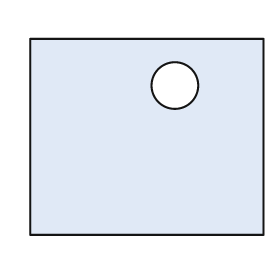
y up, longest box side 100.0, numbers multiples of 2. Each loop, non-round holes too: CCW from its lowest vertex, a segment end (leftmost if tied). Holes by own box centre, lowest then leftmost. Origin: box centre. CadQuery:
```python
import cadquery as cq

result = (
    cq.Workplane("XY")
    .moveTo(-50.0, -42.0)
    .lineTo(50.0, -42.0)
    .lineTo(50.0, 42.0)
    .lineTo(-50.0, 42.0)
    .close()
    .moveTo(12.0, 22.0)
    .circle(10.0)
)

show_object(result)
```